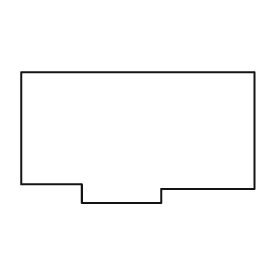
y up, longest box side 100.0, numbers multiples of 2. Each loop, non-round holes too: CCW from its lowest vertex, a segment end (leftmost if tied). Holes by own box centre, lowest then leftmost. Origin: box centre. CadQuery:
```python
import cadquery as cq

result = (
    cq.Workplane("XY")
    .moveTo(-24.0, -28.0)
    .lineTo(10.0, -28.0)
    .lineTo(10.0, -22.0)
    .lineTo(50.0, -22.0)
    .lineTo(50.0, 28.0)
    .lineTo(-50.0, 28.0)
    .lineTo(-50.0, -20.0)
    .lineTo(-24.0, -20.0)
    .close()
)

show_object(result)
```